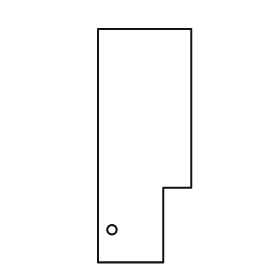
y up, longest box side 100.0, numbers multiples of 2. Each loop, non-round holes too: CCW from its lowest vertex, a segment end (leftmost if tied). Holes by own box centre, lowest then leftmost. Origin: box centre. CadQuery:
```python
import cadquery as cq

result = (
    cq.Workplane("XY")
    .moveTo(-20.0, -50.0)
    .lineTo(8.0, -50.0)
    .lineTo(8.0, -18.0)
    .lineTo(20.0, -18.0)
    .lineTo(20.0, 50.0)
    .lineTo(-20.0, 50.0)
    .close()
    .moveTo(-14.0, -36.0)
    .circle(2.0)
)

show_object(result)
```